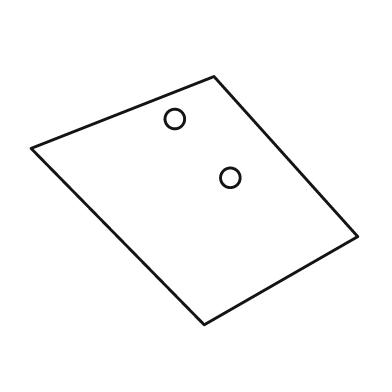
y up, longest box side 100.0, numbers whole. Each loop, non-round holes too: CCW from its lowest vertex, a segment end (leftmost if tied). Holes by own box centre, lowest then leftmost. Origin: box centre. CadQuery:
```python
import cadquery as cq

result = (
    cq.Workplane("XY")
    .moveTo(3.0, -38.0)
    .lineTo(50.0, -11.0)
    .lineTo(6.0, 38.0)
    .lineTo(-50.0, 16.0)
    .close()
    .moveTo(11.0, 7.0)
    .circle(3.0)
    .moveTo(-6.0, 25.0)
    .circle(3.0)
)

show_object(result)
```